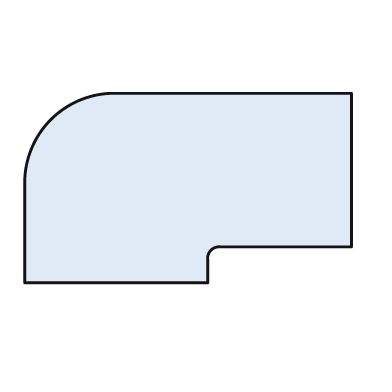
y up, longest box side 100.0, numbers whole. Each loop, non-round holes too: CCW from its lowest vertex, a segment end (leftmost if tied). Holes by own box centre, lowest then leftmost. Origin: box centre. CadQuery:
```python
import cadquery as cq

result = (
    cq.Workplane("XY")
    .moveTo(-50.0, -29.0)
    .lineTo(6.0, -29.0)
    .lineTo(6.0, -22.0)
    .threePointArc((7.0, -19.0), (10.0, -18.0))
    .lineTo(50.0, -18.0)
    .lineTo(50.0, 29.0)
    .lineTo(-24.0, 29.0)
    .threePointArc((-42.0, 21.0), (-50.0, 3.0))
    .close()
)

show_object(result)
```